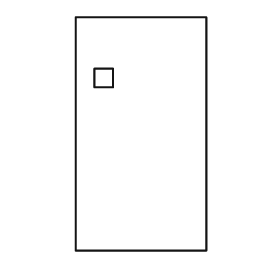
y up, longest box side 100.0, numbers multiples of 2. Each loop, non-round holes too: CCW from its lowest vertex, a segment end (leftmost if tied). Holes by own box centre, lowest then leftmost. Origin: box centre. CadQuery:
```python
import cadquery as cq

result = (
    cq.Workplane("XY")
    .moveTo(-28.0, -50.0)
    .lineTo(28.0, -50.0)
    .lineTo(28.0, 50.0)
    .lineTo(-28.0, 50.0)
    .close()
    .moveTo(-20.0, 20.0)
    .lineTo(-12.0, 20.0)
    .lineTo(-12.0, 28.0)
    .lineTo(-20.0, 28.0)
    .close()
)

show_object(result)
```